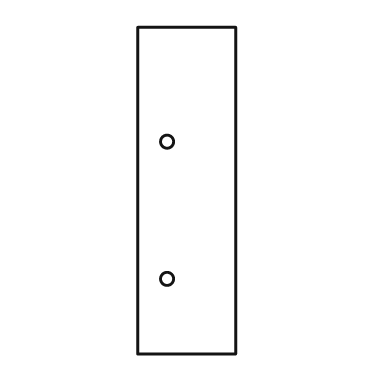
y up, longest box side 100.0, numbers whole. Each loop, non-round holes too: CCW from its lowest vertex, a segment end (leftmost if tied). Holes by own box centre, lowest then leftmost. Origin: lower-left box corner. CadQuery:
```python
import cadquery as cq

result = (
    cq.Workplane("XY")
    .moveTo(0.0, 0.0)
    .lineTo(30.0, 0.0)
    .lineTo(30.0, 100.0)
    .lineTo(0.0, 100.0)
    .close()
    .moveTo(9.0, 23.0)
    .circle(2.0)
    .moveTo(9.0, 65.0)
    .circle(2.0)
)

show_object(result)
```